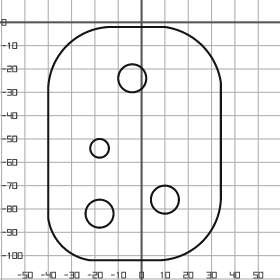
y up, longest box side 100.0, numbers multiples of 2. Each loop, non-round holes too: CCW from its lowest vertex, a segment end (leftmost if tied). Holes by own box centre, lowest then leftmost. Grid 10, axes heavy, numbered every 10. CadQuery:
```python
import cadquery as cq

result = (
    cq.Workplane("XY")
    .moveTo(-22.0, -102.0)
    .lineTo(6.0, -102.0)
    .threePointArc((26.0, -94.0), (34.0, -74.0))
    .lineTo(34.0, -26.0)
    .threePointArc((26.0, -10.0), (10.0, -2.0))
    .lineTo(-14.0, -2.0)
    .threePointArc((-32.0, -10.0), (-40.0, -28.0))
    .lineTo(-40.0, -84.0)
    .threePointArc((-34.0, -96.0), (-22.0, -102.0))
    .close()
    .moveTo(-18.0, -82.0)
    .circle(6.0)
    .moveTo(10.0, -76.0)
    .circle(6.0)
    .moveTo(-18.0, -54.0)
    .circle(4.0)
    .moveTo(-4.0, -24.0)
    .circle(6.0)
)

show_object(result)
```